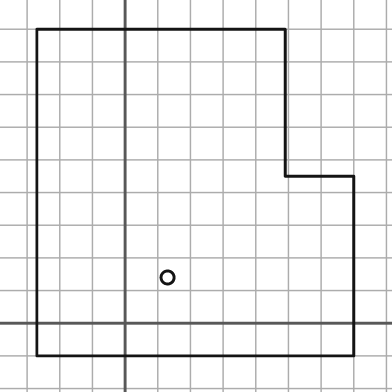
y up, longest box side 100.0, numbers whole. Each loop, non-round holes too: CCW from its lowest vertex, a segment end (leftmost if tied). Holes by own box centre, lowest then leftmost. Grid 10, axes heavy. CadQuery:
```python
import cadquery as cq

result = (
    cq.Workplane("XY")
    .moveTo(-27.0, -10.0)
    .lineTo(70.0, -10.0)
    .lineTo(70.0, 45.0)
    .lineTo(49.0, 45.0)
    .lineTo(49.0, 90.0)
    .lineTo(-27.0, 90.0)
    .close()
    .moveTo(13.0, 14.0)
    .circle(2.0)
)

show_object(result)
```